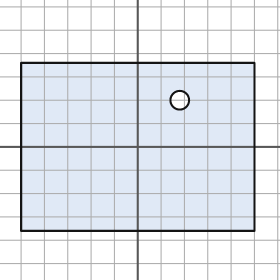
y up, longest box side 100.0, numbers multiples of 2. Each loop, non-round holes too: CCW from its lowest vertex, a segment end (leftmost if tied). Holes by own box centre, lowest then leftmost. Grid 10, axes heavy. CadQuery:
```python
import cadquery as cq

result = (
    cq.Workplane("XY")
    .moveTo(-50.0, -36.0)
    .lineTo(50.0, -36.0)
    .lineTo(50.0, 36.0)
    .lineTo(-50.0, 36.0)
    .close()
    .moveTo(18.0, 20.0)
    .circle(4.0)
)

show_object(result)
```